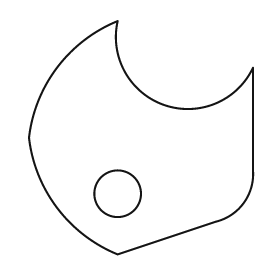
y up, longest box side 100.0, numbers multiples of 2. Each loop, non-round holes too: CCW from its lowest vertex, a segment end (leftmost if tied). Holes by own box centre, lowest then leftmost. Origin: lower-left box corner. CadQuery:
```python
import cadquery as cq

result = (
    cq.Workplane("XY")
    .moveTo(38.0, 0.0)
    .lineTo(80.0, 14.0)
    .threePointArc((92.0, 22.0), (96.0, 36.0))
    .lineTo(96.0, 80.0)
    .threePointArc((58.0, 64.0), (38.0, 100.0))
    .threePointArc((12.0, 80.0), (0.0, 50.0))
    .threePointArc((12.0, 20.0), (38.0, 0.0))
    .close()
    .moveTo(38.0, 26.0)
    .circle(10.0)
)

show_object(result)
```